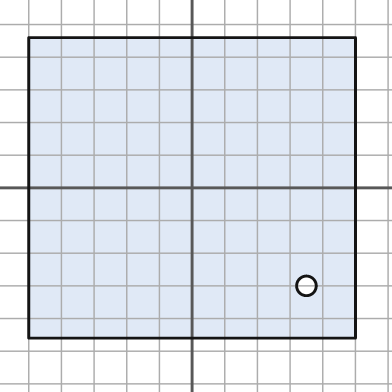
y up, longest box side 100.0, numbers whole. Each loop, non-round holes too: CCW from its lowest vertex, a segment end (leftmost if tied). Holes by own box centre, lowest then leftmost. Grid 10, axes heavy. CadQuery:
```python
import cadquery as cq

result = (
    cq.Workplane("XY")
    .moveTo(-50.0, -46.0)
    .lineTo(50.0, -46.0)
    .lineTo(50.0, 46.0)
    .lineTo(-50.0, 46.0)
    .close()
    .moveTo(35.0, -30.0)
    .circle(3.0)
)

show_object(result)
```